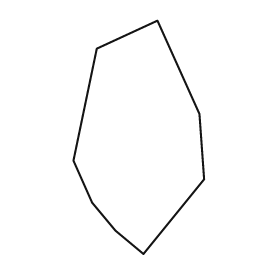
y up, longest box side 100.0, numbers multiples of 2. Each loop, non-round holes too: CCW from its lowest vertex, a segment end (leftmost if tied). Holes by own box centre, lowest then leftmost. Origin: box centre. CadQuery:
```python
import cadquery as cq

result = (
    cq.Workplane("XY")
    .moveTo(2.0, -50.0)
    .lineTo(28.0, -18.0)
    .lineTo(26.0, 10.0)
    .lineTo(8.0, 50.0)
    .lineTo(-18.0, 38.0)
    .lineTo(-28.0, -10.0)
    .lineTo(-20.0, -28.0)
    .lineTo(-10.0, -40.0)
    .close()
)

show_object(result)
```